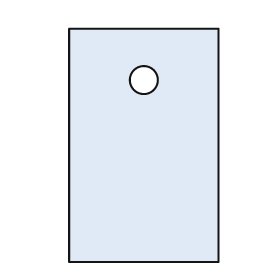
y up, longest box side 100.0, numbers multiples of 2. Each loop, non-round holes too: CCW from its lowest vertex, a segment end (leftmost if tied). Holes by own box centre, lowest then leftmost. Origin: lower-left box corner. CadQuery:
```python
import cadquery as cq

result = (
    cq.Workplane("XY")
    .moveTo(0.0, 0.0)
    .lineTo(64.0, 0.0)
    .lineTo(64.0, 100.0)
    .lineTo(0.0, 100.0)
    .close()
    .moveTo(32.0, 78.0)
    .circle(6.0)
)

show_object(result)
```